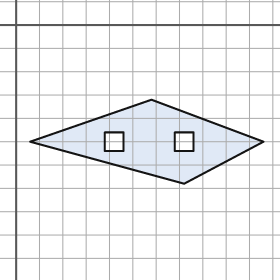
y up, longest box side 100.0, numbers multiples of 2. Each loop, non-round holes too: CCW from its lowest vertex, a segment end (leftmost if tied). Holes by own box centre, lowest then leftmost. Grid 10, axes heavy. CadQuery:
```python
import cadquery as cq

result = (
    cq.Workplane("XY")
    .moveTo(72.0, -68.0)
    .lineTo(106.0, -50.0)
    .lineTo(58.0, -32.0)
    .lineTo(6.0, -50.0)
    .close()
    .moveTo(38.0, -54.0)
    .lineTo(46.0, -54.0)
    .lineTo(46.0, -46.0)
    .lineTo(38.0, -46.0)
    .close()
    .moveTo(68.0, -54.0)
    .lineTo(76.0, -54.0)
    .lineTo(76.0, -46.0)
    .lineTo(68.0, -46.0)
    .close()
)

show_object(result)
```